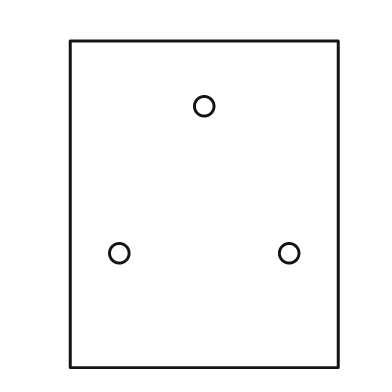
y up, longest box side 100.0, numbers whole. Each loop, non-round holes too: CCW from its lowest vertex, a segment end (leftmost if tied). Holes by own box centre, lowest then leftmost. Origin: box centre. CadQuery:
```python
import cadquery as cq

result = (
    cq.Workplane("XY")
    .moveTo(-41.0, -50.0)
    .lineTo(41.0, -50.0)
    .lineTo(41.0, 50.0)
    .lineTo(-41.0, 50.0)
    .close()
    .moveTo(-26.0, -15.0)
    .circle(3.0)
    .moveTo(26.0, -15.0)
    .circle(3.0)
    .moveTo(0.0, 30.0)
    .circle(3.0)
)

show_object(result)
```